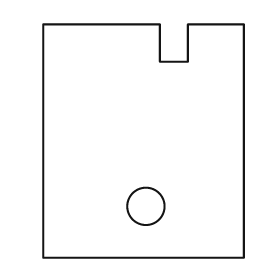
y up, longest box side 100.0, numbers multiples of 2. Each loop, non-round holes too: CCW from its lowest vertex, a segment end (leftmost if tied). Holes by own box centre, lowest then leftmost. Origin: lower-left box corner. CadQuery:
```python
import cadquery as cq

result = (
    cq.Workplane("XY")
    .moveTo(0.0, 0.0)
    .lineTo(86.0, 0.0)
    .lineTo(86.0, 100.0)
    .lineTo(62.0, 100.0)
    .lineTo(62.0, 84.0)
    .lineTo(50.0, 84.0)
    .lineTo(50.0, 100.0)
    .lineTo(0.0, 100.0)
    .close()
    .moveTo(44.0, 22.0)
    .circle(8.0)
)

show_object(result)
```